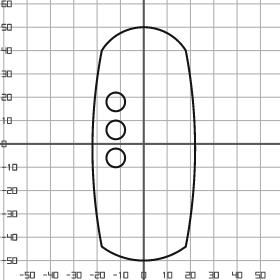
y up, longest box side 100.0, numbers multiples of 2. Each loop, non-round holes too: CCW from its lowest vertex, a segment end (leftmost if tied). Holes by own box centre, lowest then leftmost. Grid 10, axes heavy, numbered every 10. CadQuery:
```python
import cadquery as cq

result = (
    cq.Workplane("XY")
    .moveTo(-18.0, -44.0)
    .threePointArc((0.0, -50.0), (18.0, -44.0))
    .threePointArc((22.0, -2.0), (18.0, 40.0))
    .threePointArc((0.0, 50.0), (-18.0, 40.0))
    .threePointArc((-22.0, -2.0), (-18.0, -44.0))
    .close()
    .moveTo(-12.0, -6.0)
    .circle(4.0)
    .moveTo(-12.0, 6.0)
    .circle(4.0)
    .moveTo(-12.0, 18.0)
    .circle(4.0)
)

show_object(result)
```